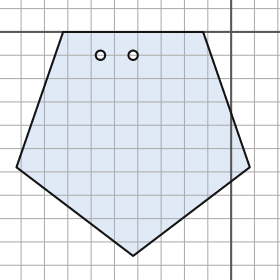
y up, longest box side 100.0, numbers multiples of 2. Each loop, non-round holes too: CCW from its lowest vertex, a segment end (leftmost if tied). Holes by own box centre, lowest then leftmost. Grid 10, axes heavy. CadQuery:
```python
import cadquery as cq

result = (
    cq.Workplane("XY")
    .moveTo(-42.0, -96.0)
    .lineTo(8.0, -58.0)
    .lineTo(-12.0, 0.0)
    .lineTo(-72.0, 0.0)
    .lineTo(-92.0, -58.0)
    .close()
    .moveTo(-56.0, -10.0)
    .circle(2.0)
    .moveTo(-42.0, -10.0)
    .circle(2.0)
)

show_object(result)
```